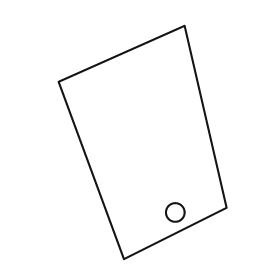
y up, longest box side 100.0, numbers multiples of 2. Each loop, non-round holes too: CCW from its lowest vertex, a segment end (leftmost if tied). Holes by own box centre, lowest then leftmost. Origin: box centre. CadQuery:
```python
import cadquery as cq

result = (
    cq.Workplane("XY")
    .moveTo(-8.0, -50.0)
    .lineTo(36.0, -28.0)
    .lineTo(18.0, 50.0)
    .lineTo(-36.0, 26.0)
    .close()
    .moveTo(14.0, -30.0)
    .circle(4.0)
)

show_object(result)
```